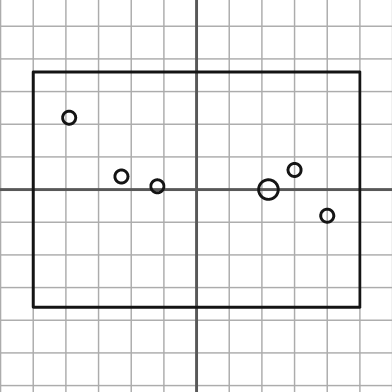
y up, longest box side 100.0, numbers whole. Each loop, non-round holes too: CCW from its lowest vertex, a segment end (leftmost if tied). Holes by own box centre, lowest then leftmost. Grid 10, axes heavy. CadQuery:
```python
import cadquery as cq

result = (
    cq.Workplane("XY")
    .moveTo(-50.0, -36.0)
    .lineTo(50.0, -36.0)
    .lineTo(50.0, 36.0)
    .lineTo(-50.0, 36.0)
    .close()
    .moveTo(40.0, -8.0)
    .circle(2.0)
    .moveTo(22.0, 0.0)
    .circle(3.0)
    .moveTo(-12.0, 1.0)
    .circle(2.0)
    .moveTo(-23.0, 4.0)
    .circle(2.0)
    .moveTo(30.0, 6.0)
    .circle(2.0)
    .moveTo(-39.0, 22.0)
    .circle(2.0)
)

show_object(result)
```